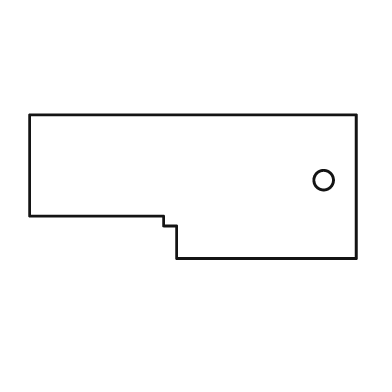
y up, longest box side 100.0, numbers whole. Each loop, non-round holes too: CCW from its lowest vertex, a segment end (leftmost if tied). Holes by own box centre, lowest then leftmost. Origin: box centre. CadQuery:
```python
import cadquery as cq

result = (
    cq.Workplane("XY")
    .moveTo(-5.0, -22.0)
    .lineTo(50.0, -22.0)
    .lineTo(50.0, 22.0)
    .lineTo(-50.0, 22.0)
    .lineTo(-50.0, -9.0)
    .lineTo(-9.0, -9.0)
    .lineTo(-9.0, -12.0)
    .lineTo(-5.0, -12.0)
    .close()
    .moveTo(40.0, 2.0)
    .circle(3.0)
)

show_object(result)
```